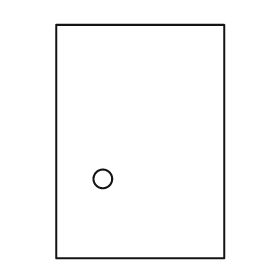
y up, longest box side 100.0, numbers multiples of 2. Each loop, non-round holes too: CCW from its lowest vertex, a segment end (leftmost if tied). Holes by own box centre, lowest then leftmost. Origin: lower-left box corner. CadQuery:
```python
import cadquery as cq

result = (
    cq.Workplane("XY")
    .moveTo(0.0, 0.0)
    .lineTo(72.0, 0.0)
    .lineTo(72.0, 100.0)
    .lineTo(0.0, 100.0)
    .close()
    .moveTo(20.0, 34.0)
    .circle(4.0)
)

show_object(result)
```